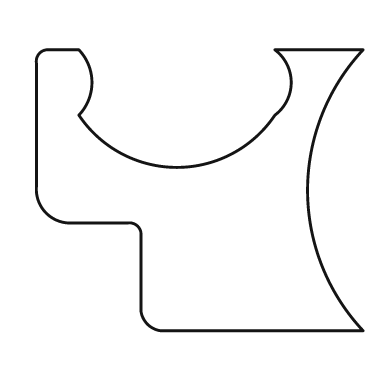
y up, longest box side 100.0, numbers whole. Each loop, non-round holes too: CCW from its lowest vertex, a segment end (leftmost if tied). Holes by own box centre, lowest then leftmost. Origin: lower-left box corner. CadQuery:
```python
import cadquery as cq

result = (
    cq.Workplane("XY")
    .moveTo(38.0, 0.0)
    .lineTo(100.0, 0.0)
    .threePointArc((83.0, 43.0), (100.0, 86.0))
    .lineTo(73.0, 86.0)
    .threePointArc((78.0, 76.0), (73.0, 66.0))
    .threePointArc((43.0, 50.0), (13.0, 66.0))
    .threePointArc((17.0, 76.0), (13.0, 86.0))
    .lineTo(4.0, 86.0)
    .threePointArc((1.0, 85.0), (0.0, 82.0))
    .lineTo(0.0, 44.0)
    .threePointArc((3.0, 36.0), (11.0, 33.0))
    .lineTo(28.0, 33.0)
    .threePointArc((31.0, 32.0), (32.0, 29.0))
    .lineTo(32.0, 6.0)
    .threePointArc((34.0, 2.0), (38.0, 0.0))
    .close()
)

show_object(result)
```